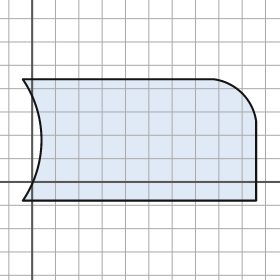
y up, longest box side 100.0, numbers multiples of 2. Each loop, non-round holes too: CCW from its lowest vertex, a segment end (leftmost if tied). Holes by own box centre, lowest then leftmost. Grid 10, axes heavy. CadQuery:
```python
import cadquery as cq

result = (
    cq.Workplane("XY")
    .moveTo(-4.0, -8.0)
    .lineTo(96.0, -8.0)
    .lineTo(96.0, 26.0)
    .threePointArc((90.0, 38.0), (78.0, 44.0))
    .lineTo(-4.0, 44.0)
    .threePointArc((4.0, 18.0), (-4.0, -8.0))
    .close()
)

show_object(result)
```